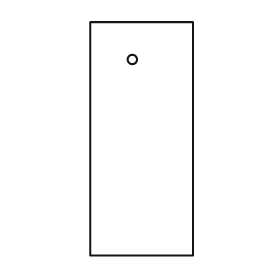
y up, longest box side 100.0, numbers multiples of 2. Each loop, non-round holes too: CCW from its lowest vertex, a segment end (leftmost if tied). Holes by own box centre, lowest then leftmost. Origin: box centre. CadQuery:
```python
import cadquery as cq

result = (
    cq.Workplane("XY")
    .moveTo(-22.0, -50.0)
    .lineTo(22.0, -50.0)
    .lineTo(22.0, 50.0)
    .lineTo(-22.0, 50.0)
    .close()
    .moveTo(-4.0, 34.0)
    .circle(2.0)
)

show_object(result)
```